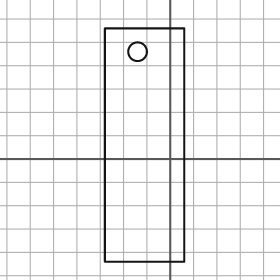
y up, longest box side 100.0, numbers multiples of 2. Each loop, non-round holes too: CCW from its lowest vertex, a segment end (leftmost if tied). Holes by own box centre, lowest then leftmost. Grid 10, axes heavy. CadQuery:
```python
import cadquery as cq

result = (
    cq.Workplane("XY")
    .moveTo(-28.0, -44.0)
    .lineTo(6.0, -44.0)
    .lineTo(6.0, 56.0)
    .lineTo(-28.0, 56.0)
    .close()
    .moveTo(-14.0, 46.0)
    .circle(4.0)
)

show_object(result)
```